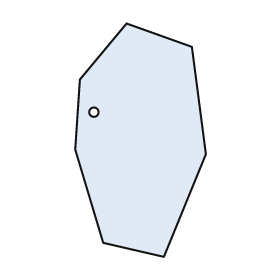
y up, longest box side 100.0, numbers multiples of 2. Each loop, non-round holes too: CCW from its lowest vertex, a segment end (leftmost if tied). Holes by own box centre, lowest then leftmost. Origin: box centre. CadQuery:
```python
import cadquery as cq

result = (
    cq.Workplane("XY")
    .moveTo(10.0, -50.0)
    .lineTo(28.0, -6.0)
    .lineTo(22.0, 40.0)
    .lineTo(-6.0, 50.0)
    .lineTo(-26.0, 26.0)
    .lineTo(-28.0, -4.0)
    .lineTo(-16.0, -44.0)
    .close()
    .moveTo(-20.0, 12.0)
    .circle(2.0)
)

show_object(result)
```